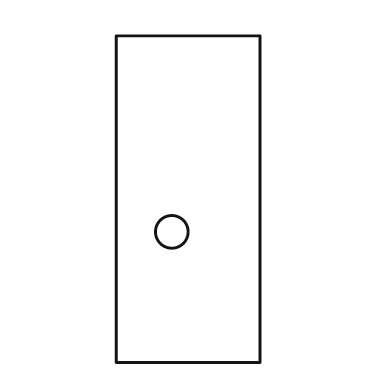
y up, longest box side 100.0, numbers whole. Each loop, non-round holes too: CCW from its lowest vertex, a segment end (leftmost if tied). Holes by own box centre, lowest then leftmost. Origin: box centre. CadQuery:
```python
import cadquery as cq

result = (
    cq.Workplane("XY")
    .moveTo(-22.0, -50.0)
    .lineTo(22.0, -50.0)
    .lineTo(22.0, 50.0)
    .lineTo(-22.0, 50.0)
    .close()
    .moveTo(-5.0, -10.0)
    .circle(5.0)
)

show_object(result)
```